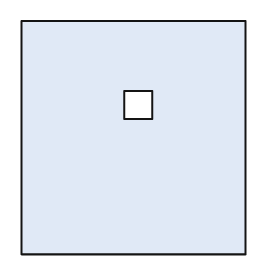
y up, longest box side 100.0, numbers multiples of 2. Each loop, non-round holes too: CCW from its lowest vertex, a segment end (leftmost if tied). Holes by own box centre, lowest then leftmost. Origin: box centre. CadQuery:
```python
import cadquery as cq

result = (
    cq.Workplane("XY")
    .moveTo(-48.0, -50.0)
    .lineTo(48.0, -50.0)
    .lineTo(48.0, 50.0)
    .lineTo(-48.0, 50.0)
    .close()
    .moveTo(-4.0, 8.0)
    .lineTo(8.0, 8.0)
    .lineTo(8.0, 20.0)
    .lineTo(-4.0, 20.0)
    .close()
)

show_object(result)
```